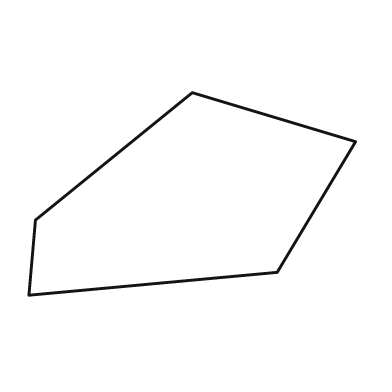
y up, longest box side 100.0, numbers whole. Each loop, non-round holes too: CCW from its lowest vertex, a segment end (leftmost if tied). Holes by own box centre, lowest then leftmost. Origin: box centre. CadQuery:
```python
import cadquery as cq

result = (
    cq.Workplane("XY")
    .moveTo(-50.0, -31.0)
    .lineTo(26.0, -24.0)
    .lineTo(50.0, 16.0)
    .lineTo(0.0, 31.0)
    .lineTo(-48.0, -8.0)
    .close()
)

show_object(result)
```